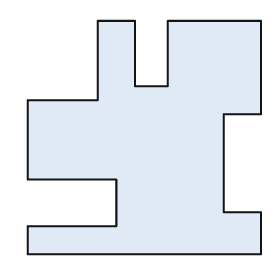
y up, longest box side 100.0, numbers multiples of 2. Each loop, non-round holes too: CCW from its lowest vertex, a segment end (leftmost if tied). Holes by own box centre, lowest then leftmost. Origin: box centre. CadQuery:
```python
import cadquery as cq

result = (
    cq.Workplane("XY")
    .moveTo(-50.0, -50.0)
    .lineTo(50.0, -50.0)
    .lineTo(50.0, -32.0)
    .lineTo(34.0, -32.0)
    .lineTo(34.0, 10.0)
    .lineTo(50.0, 10.0)
    .lineTo(50.0, 50.0)
    .lineTo(10.0, 50.0)
    .lineTo(10.0, 22.0)
    .lineTo(-4.0, 22.0)
    .lineTo(-4.0, 50.0)
    .lineTo(-20.0, 50.0)
    .lineTo(-20.0, 16.0)
    .lineTo(-50.0, 16.0)
    .lineTo(-50.0, -18.0)
    .lineTo(-12.0, -18.0)
    .lineTo(-12.0, -38.0)
    .lineTo(-50.0, -38.0)
    .close()
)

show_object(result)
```